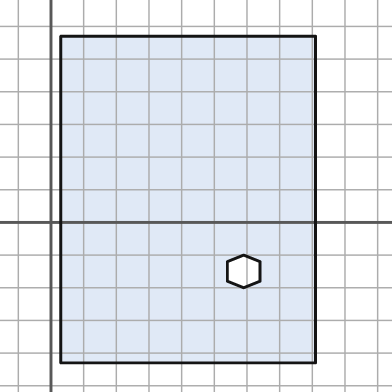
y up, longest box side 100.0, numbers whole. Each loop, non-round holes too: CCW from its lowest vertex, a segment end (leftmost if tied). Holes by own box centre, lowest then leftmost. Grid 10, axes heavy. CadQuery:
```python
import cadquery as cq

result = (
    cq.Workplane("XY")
    .moveTo(3.0, -43.0)
    .lineTo(81.0, -43.0)
    .lineTo(81.0, 57.0)
    .lineTo(3.0, 57.0)
    .close()
    .moveTo(59.0, -20.0)
    .lineTo(64.0, -18.0)
    .lineTo(64.0, -12.0)
    .lineTo(59.0, -10.0)
    .lineTo(54.0, -12.0)
    .lineTo(54.0, -18.0)
    .close()
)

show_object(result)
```